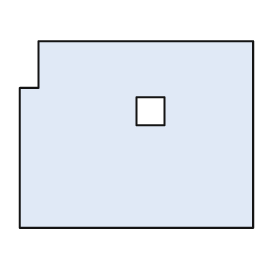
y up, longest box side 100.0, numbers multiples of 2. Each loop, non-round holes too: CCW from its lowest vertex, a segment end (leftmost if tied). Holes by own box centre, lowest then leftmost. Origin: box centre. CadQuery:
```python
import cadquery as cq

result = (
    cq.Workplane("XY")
    .moveTo(-50.0, -40.0)
    .lineTo(50.0, -40.0)
    .lineTo(50.0, 40.0)
    .lineTo(-42.0, 40.0)
    .lineTo(-42.0, 20.0)
    .lineTo(-50.0, 20.0)
    .close()
    .moveTo(0.0, 4.0)
    .lineTo(12.0, 4.0)
    .lineTo(12.0, 16.0)
    .lineTo(0.0, 16.0)
    .close()
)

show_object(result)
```